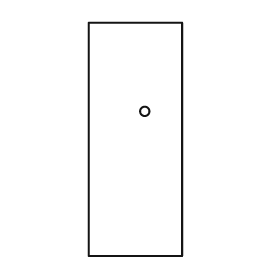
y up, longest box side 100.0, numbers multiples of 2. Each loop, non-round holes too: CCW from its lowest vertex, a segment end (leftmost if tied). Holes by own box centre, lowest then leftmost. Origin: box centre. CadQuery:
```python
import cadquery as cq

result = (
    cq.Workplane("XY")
    .moveTo(-20.0, -50.0)
    .lineTo(20.0, -50.0)
    .lineTo(20.0, 50.0)
    .lineTo(-20.0, 50.0)
    .close()
    .moveTo(4.0, 12.0)
    .circle(2.0)
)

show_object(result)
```